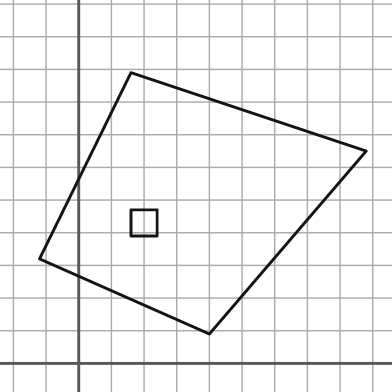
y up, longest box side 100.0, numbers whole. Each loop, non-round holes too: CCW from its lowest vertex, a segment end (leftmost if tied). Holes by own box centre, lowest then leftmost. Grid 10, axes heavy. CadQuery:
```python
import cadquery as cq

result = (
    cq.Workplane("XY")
    .moveTo(40.0, 9.0)
    .lineTo(88.0, 65.0)
    .lineTo(16.0, 89.0)
    .lineTo(-12.0, 32.0)
    .close()
    .moveTo(16.0, 39.0)
    .lineTo(24.0, 39.0)
    .lineTo(24.0, 47.0)
    .lineTo(16.0, 47.0)
    .close()
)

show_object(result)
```